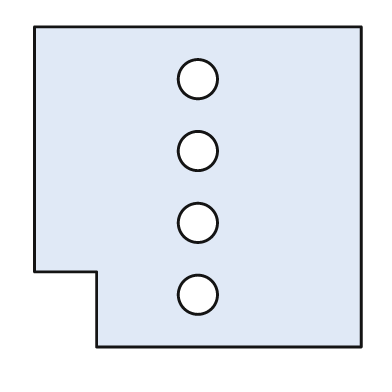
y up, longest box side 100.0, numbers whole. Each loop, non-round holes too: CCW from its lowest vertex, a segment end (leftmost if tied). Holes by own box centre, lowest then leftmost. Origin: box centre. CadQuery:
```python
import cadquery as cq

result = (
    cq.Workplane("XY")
    .moveTo(-31.0, -49.0)
    .lineTo(50.0, -49.0)
    .lineTo(50.0, 49.0)
    .lineTo(-50.0, 49.0)
    .lineTo(-50.0, -26.0)
    .lineTo(-31.0, -26.0)
    .close()
    .moveTo(0.0, -33.0)
    .circle(6.0)
    .moveTo(0.0, -11.0)
    .circle(6.0)
    .moveTo(0.0, 11.0)
    .circle(6.0)
    .moveTo(0.0, 33.0)
    .circle(6.0)
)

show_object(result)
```